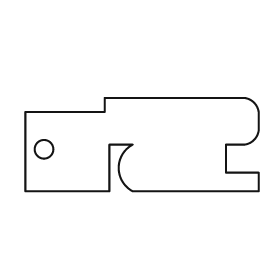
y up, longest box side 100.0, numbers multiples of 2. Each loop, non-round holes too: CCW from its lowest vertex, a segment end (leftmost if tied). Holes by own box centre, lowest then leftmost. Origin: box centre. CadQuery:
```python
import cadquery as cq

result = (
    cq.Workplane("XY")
    .moveTo(-50.0, -20.0)
    .lineTo(-14.0, -20.0)
    .lineTo(-14.0, 0.0)
    .lineTo(-4.0, 0.0)
    .threePointArc((-10.0, -10.0), (-4.0, -20.0))
    .lineTo(50.0, -20.0)
    .lineTo(50.0, -12.0)
    .lineTo(36.0, -12.0)
    .lineTo(36.0, 0.0)
    .lineTo(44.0, 0.0)
    .threePointArc((48.0, 2.0), (50.0, 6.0))
    .lineTo(50.0, 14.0)
    .threePointArc((48.0, 18.0), (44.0, 20.0))
    .lineTo(-16.0, 20.0)
    .lineTo(-16.0, 14.0)
    .lineTo(-50.0, 14.0)
    .close()
    .moveTo(-42.0, -2.0)
    .circle(4.0)
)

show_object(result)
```